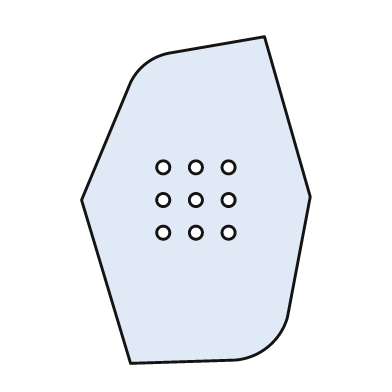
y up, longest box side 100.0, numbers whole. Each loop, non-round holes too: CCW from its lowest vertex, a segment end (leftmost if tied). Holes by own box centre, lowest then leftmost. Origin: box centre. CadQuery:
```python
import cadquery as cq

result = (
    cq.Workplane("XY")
    .moveTo(-20.0, -50.0)
    .lineTo(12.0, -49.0)
    .threePointArc((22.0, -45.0), (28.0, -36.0))
    .lineTo(35.0, 1.0)
    .lineTo(21.0, 50.0)
    .lineTo(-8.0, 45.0)
    .threePointArc((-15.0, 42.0), (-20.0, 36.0))
    .lineTo(-35.0, 0.0)
    .close()
    .moveTo(-10.0, -10.0)
    .circle(2.0)
    .moveTo(0.0, -10.0)
    .circle(2.0)
    .moveTo(10.0, -10.0)
    .circle(2.0)
    .moveTo(-10.0, 0.0)
    .circle(2.0)
    .moveTo(0.0, 0.0)
    .circle(2.0)
    .moveTo(10.0, 0.0)
    .circle(2.0)
    .moveTo(-10.0, 10.0)
    .circle(2.0)
    .moveTo(0.0, 10.0)
    .circle(2.0)
    .moveTo(10.0, 10.0)
    .circle(2.0)
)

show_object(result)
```